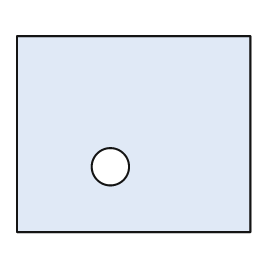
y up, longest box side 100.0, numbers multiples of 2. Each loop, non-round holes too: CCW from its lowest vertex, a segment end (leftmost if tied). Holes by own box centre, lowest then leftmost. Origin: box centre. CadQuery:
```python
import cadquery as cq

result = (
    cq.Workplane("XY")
    .moveTo(-50.0, -42.0)
    .lineTo(50.0, -42.0)
    .lineTo(50.0, 42.0)
    .lineTo(-50.0, 42.0)
    .close()
    .moveTo(-10.0, -14.0)
    .circle(8.0)
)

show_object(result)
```